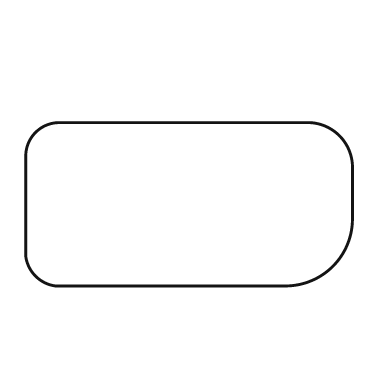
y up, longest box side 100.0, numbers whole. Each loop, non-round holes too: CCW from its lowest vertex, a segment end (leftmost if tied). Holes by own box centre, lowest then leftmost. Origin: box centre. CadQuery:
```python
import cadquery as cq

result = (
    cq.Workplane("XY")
    .moveTo(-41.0, -25.0)
    .lineTo(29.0, -25.0)
    .threePointArc((44.0, -19.0), (50.0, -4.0))
    .lineTo(50.0, 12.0)
    .threePointArc((46.0, 21.0), (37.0, 25.0))
    .lineTo(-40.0, 25.0)
    .threePointArc((-47.0, 22.0), (-50.0, 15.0))
    .lineTo(-50.0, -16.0)
    .threePointArc((-47.0, -22.0), (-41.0, -25.0))
    .close()
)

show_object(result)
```